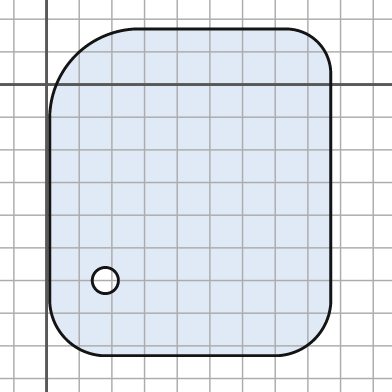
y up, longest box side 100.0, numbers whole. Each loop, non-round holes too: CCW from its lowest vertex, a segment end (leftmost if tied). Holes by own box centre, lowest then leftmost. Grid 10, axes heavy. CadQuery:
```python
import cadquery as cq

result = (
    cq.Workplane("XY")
    .moveTo(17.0, -83.0)
    .lineTo(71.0, -83.0)
    .threePointArc((82.0, -78.0), (87.0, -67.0))
    .lineTo(87.0, 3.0)
    .threePointArc((83.0, 13.0), (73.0, 17.0))
    .lineTo(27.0, 17.0)
    .threePointArc((9.0, 9.0), (1.0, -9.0))
    .lineTo(1.0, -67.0)
    .threePointArc((6.0, -78.0), (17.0, -83.0))
    .close()
    .moveTo(18.0, -60.0)
    .circle(4.0)
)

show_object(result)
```